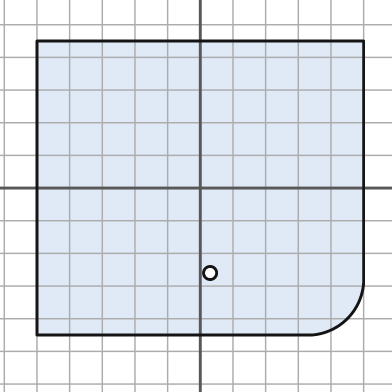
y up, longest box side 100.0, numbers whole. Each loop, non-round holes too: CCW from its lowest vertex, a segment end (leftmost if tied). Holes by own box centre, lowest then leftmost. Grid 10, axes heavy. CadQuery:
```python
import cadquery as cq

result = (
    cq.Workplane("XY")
    .moveTo(-50.0, -45.0)
    .lineTo(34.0, -45.0)
    .threePointArc((45.0, -40.0), (50.0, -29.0))
    .lineTo(50.0, 45.0)
    .lineTo(-50.0, 45.0)
    .close()
    .moveTo(3.0, -26.0)
    .circle(2.0)
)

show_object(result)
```